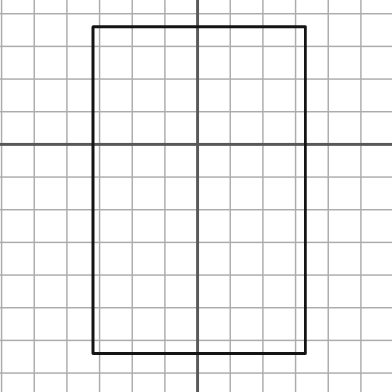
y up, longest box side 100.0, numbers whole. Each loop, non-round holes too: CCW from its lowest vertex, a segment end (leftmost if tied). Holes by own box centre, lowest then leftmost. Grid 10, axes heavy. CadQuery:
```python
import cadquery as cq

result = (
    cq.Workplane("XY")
    .moveTo(-32.0, -64.0)
    .lineTo(33.0, -64.0)
    .lineTo(33.0, 36.0)
    .lineTo(-32.0, 36.0)
    .close()
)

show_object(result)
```